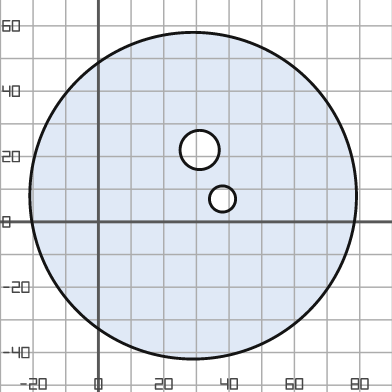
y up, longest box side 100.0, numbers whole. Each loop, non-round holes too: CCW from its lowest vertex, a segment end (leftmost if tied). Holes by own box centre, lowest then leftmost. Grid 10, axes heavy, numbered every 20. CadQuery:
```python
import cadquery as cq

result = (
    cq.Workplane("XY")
    .moveTo(29.0, 8.0)
    .circle(50.0)
    .moveTo(38.0, 7.0)
    .circle(4.0)
    .moveTo(31.0, 22.0)
    .circle(6.0)
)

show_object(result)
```